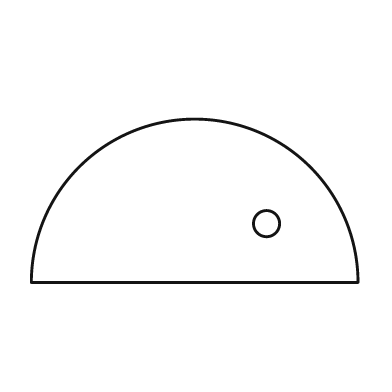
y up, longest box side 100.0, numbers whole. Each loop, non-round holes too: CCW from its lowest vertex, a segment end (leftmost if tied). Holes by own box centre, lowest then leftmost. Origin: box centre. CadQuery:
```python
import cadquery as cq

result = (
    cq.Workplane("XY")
    .moveTo(-50.0, -25.0)
    .lineTo(50.0, -25.0)
    .threePointArc((0.0, 25.0), (-50.0, -25.0))
    .close()
    .moveTo(22.0, -7.0)
    .circle(4.0)
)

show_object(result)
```